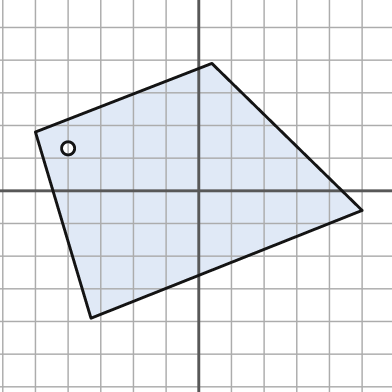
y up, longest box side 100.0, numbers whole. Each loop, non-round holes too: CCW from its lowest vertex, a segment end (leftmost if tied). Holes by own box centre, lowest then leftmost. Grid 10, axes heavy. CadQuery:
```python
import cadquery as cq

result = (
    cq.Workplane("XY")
    .moveTo(-33.0, -39.0)
    .lineTo(50.0, -6.0)
    .lineTo(4.0, 39.0)
    .lineTo(-50.0, 18.0)
    .close()
    .moveTo(-40.0, 13.0)
    .circle(2.0)
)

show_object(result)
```